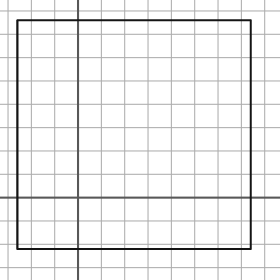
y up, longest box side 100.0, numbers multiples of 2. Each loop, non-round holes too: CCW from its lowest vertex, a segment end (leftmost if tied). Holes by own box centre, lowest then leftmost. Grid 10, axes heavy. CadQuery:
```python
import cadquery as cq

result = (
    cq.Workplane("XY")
    .moveTo(-26.0, -22.0)
    .lineTo(74.0, -22.0)
    .lineTo(74.0, 76.0)
    .lineTo(-26.0, 76.0)
    .close()
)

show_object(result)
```